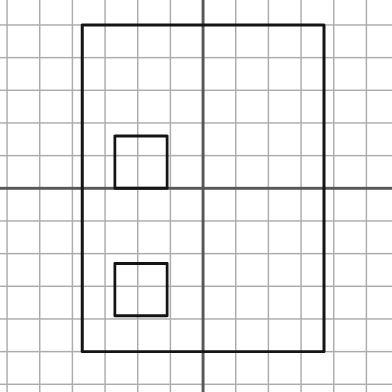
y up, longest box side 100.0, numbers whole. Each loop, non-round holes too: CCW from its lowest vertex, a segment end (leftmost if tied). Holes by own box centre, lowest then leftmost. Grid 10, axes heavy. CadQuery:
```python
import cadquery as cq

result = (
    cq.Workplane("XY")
    .moveTo(-37.0, -50.0)
    .lineTo(37.0, -50.0)
    .lineTo(37.0, 50.0)
    .lineTo(-37.0, 50.0)
    .close()
    .moveTo(-27.0, -39.0)
    .lineTo(-11.0, -39.0)
    .lineTo(-11.0, -23.0)
    .lineTo(-27.0, -23.0)
    .close()
    .moveTo(-27.0, 0.0)
    .lineTo(-11.0, 0.0)
    .lineTo(-11.0, 16.0)
    .lineTo(-27.0, 16.0)
    .close()
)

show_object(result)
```